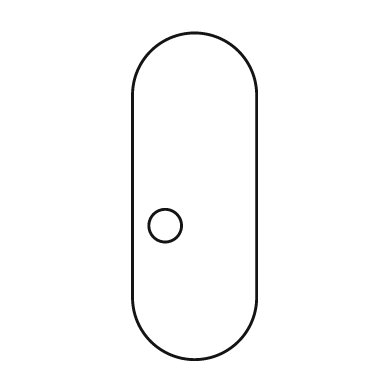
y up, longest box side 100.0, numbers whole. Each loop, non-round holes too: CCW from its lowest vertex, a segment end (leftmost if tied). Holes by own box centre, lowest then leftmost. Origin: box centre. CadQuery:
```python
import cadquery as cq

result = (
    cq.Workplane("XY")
    .moveTo(-19.0, -31.0)
    .threePointArc((0.0, -50.0), (19.0, -31.0))
    .lineTo(19.0, 31.0)
    .threePointArc((0.0, 50.0), (-19.0, 31.0))
    .close()
    .moveTo(-9.0, -9.0)
    .circle(5.0)
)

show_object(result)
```